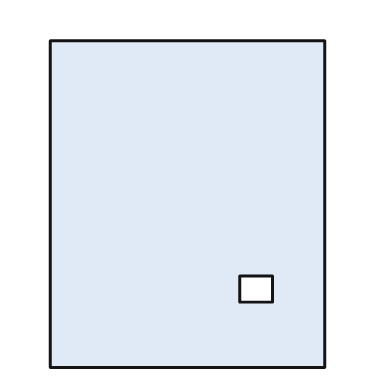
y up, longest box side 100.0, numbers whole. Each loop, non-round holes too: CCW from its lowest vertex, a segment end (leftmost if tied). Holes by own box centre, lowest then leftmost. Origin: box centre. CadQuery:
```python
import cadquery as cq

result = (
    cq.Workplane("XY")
    .moveTo(-42.0, -50.0)
    .lineTo(42.0, -50.0)
    .lineTo(42.0, 50.0)
    .lineTo(-42.0, 50.0)
    .close()
    .moveTo(16.0, -30.0)
    .lineTo(26.0, -30.0)
    .lineTo(26.0, -22.0)
    .lineTo(16.0, -22.0)
    .close()
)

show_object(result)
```